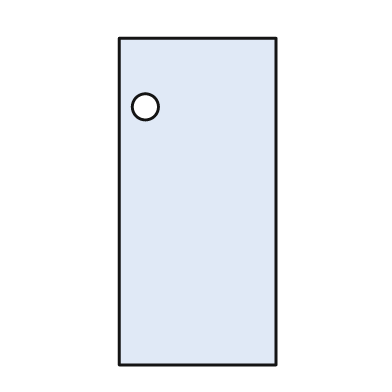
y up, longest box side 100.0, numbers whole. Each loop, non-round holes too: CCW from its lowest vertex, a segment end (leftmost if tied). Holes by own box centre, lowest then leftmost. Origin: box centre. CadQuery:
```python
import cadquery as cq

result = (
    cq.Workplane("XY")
    .moveTo(-24.0, -50.0)
    .lineTo(24.0, -50.0)
    .lineTo(24.0, 50.0)
    .lineTo(-24.0, 50.0)
    .close()
    .moveTo(-16.0, 29.0)
    .circle(4.0)
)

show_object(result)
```